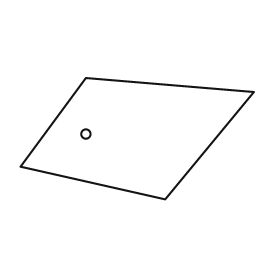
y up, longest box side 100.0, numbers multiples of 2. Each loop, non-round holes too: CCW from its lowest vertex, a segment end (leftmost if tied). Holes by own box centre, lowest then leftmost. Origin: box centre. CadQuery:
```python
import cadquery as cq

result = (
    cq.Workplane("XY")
    .moveTo(12.0, -26.0)
    .lineTo(50.0, 20.0)
    .lineTo(-22.0, 26.0)
    .lineTo(-50.0, -12.0)
    .close()
    .moveTo(-22.0, 2.0)
    .circle(2.0)
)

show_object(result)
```